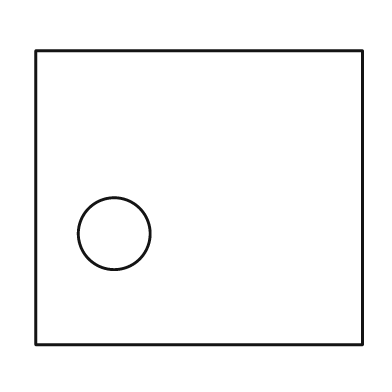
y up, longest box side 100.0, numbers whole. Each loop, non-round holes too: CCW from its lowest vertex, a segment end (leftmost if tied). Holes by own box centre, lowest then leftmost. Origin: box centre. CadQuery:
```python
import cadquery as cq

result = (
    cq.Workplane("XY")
    .moveTo(-50.0, -45.0)
    .lineTo(50.0, -45.0)
    .lineTo(50.0, 45.0)
    .lineTo(-50.0, 45.0)
    .close()
    .moveTo(-26.0, -11.0)
    .circle(11.0)
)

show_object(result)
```